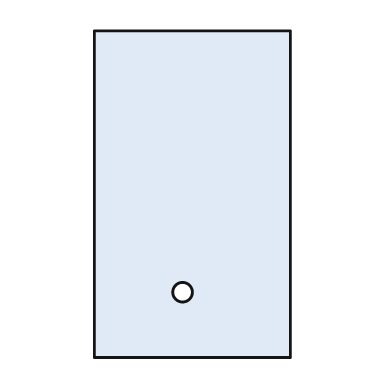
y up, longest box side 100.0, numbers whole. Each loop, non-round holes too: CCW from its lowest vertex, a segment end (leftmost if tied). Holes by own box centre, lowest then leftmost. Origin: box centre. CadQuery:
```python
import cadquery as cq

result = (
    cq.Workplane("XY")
    .moveTo(-30.0, -50.0)
    .lineTo(30.0, -50.0)
    .lineTo(30.0, 50.0)
    .lineTo(-30.0, 50.0)
    .close()
    .moveTo(-3.0, -30.0)
    .circle(3.0)
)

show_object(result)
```